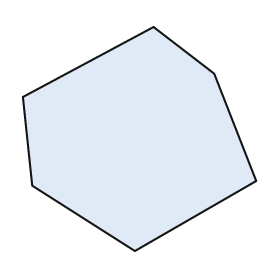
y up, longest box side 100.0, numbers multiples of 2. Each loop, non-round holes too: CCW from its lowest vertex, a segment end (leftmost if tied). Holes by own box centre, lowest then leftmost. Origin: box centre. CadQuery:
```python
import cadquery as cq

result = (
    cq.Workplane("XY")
    .moveTo(-2.0, -48.0)
    .lineTo(50.0, -18.0)
    .lineTo(32.0, 28.0)
    .lineTo(6.0, 48.0)
    .lineTo(-50.0, 18.0)
    .lineTo(-46.0, -20.0)
    .close()
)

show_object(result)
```